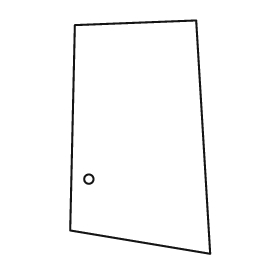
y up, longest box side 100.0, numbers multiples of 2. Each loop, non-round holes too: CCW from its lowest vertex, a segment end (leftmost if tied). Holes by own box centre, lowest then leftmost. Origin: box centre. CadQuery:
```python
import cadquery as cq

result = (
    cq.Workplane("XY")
    .moveTo(30.0, -50.0)
    .lineTo(24.0, 50.0)
    .lineTo(-28.0, 48.0)
    .lineTo(-30.0, -40.0)
    .close()
    .moveTo(-22.0, -18.0)
    .circle(2.0)
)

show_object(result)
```